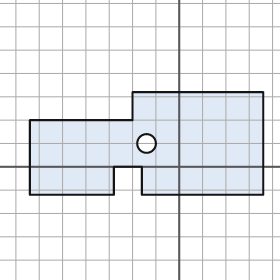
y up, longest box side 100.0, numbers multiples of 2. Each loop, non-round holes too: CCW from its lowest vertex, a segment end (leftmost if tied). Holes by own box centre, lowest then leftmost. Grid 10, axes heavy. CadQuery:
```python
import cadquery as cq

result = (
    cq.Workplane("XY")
    .moveTo(-64.0, -12.0)
    .lineTo(-28.0, -12.0)
    .lineTo(-28.0, 0.0)
    .lineTo(-16.0, 0.0)
    .lineTo(-16.0, -12.0)
    .lineTo(36.0, -12.0)
    .lineTo(36.0, 32.0)
    .lineTo(-20.0, 32.0)
    .lineTo(-20.0, 20.0)
    .lineTo(-64.0, 20.0)
    .close()
    .moveTo(-14.0, 10.0)
    .circle(4.0)
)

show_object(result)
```